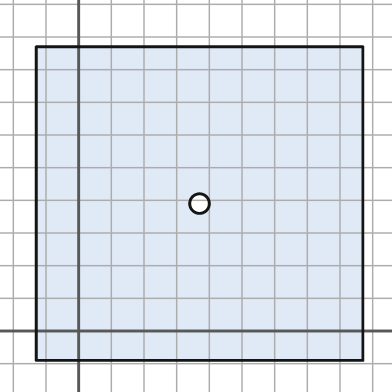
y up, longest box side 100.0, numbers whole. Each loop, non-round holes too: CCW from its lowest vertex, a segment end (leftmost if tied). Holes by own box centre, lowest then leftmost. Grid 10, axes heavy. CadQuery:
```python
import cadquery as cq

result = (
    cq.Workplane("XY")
    .moveTo(-13.0, -9.0)
    .lineTo(87.0, -9.0)
    .lineTo(87.0, 87.0)
    .lineTo(-13.0, 87.0)
    .close()
    .moveTo(37.0, 39.0)
    .circle(3.0)
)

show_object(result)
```